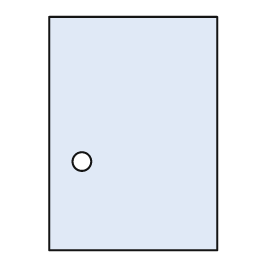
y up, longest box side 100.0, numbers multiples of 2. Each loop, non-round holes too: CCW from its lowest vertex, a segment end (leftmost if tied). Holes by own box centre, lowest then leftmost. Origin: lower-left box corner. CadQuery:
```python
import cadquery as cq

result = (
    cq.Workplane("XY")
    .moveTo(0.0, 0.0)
    .lineTo(72.0, 0.0)
    .lineTo(72.0, 100.0)
    .lineTo(0.0, 100.0)
    .close()
    .moveTo(14.0, 38.0)
    .circle(4.0)
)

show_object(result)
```